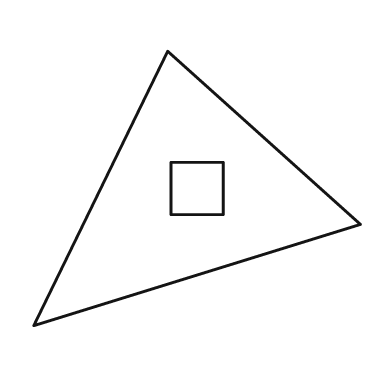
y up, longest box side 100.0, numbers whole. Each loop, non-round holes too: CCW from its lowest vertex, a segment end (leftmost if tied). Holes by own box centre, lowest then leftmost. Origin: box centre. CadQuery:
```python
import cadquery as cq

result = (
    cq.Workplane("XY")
    .moveTo(-50.0, -42.0)
    .lineTo(50.0, -11.0)
    .lineTo(-9.0, 42.0)
    .close()
    .moveTo(-8.0, -8.0)
    .lineTo(8.0, -8.0)
    .lineTo(8.0, 8.0)
    .lineTo(-8.0, 8.0)
    .close()
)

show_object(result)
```